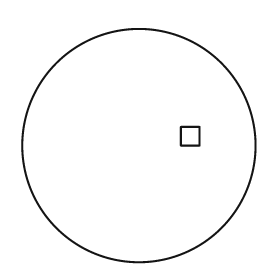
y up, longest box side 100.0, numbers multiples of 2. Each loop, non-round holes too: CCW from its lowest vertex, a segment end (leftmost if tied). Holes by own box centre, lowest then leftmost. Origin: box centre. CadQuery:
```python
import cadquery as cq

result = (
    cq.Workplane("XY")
    .moveTo(0.0, 0.0)
    .circle(50.0)
    .moveTo(18.0, 0.0)
    .lineTo(26.0, 0.0)
    .lineTo(26.0, 8.0)
    .lineTo(18.0, 8.0)
    .close()
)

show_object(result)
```